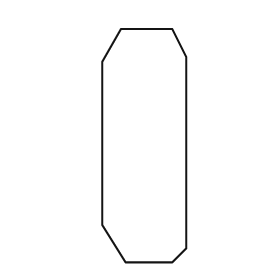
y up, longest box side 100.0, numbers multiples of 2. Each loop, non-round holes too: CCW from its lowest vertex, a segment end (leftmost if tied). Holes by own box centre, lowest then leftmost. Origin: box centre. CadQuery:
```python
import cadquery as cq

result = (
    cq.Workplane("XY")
    .moveTo(-8.0, -50.0)
    .lineTo(12.0, -50.0)
    .lineTo(18.0, -44.0)
    .lineTo(18.0, 38.0)
    .lineTo(12.0, 50.0)
    .lineTo(-10.0, 50.0)
    .lineTo(-18.0, 36.0)
    .lineTo(-18.0, -34.0)
    .close()
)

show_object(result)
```